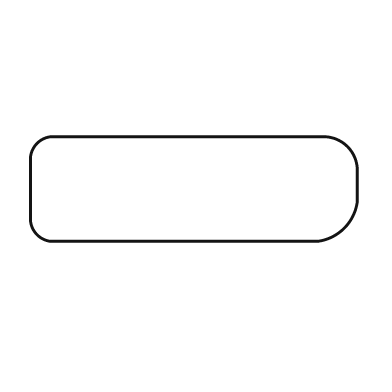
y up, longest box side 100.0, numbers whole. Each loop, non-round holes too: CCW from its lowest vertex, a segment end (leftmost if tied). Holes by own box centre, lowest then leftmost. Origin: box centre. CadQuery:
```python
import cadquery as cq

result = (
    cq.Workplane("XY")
    .moveTo(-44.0, -16.0)
    .lineTo(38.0, -16.0)
    .threePointArc((46.0, -12.0), (50.0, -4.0))
    .lineTo(50.0, 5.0)
    .threePointArc((47.0, 13.0), (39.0, 16.0))
    .lineTo(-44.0, 16.0)
    .threePointArc((-48.0, 14.0), (-50.0, 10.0))
    .lineTo(-50.0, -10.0)
    .threePointArc((-48.0, -14.0), (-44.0, -16.0))
    .close()
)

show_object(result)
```